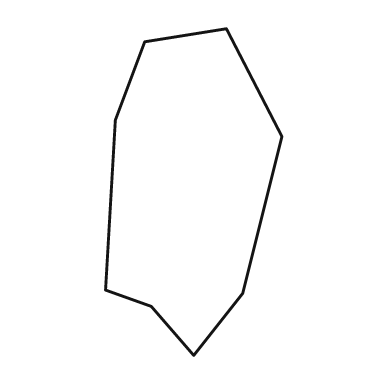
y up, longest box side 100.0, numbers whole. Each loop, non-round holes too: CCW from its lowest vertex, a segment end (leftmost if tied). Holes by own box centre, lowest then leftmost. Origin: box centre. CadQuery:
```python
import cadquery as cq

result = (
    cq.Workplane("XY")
    .moveTo(0.0, -50.0)
    .lineTo(15.0, -31.0)
    .lineTo(27.0, 17.0)
    .lineTo(10.0, 50.0)
    .lineTo(-15.0, 46.0)
    .lineTo(-24.0, 22.0)
    .lineTo(-27.0, -30.0)
    .lineTo(-13.0, -35.0)
    .close()
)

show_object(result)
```